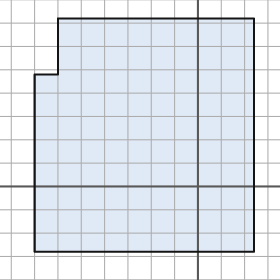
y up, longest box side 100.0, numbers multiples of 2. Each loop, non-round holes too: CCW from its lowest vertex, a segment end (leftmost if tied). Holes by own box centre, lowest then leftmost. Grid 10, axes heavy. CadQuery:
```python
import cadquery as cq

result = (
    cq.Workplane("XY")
    .moveTo(-70.0, -28.0)
    .lineTo(24.0, -28.0)
    .lineTo(24.0, 72.0)
    .lineTo(-60.0, 72.0)
    .lineTo(-60.0, 48.0)
    .lineTo(-70.0, 48.0)
    .close()
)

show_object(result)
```